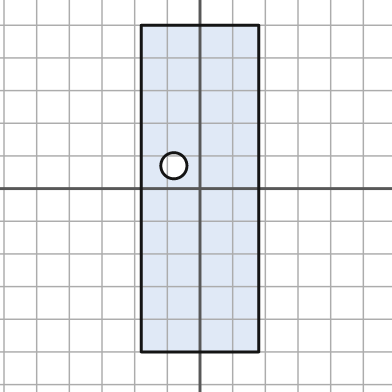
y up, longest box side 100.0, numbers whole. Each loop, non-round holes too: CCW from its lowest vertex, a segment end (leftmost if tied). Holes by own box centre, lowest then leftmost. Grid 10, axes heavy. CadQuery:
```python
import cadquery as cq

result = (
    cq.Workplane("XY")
    .moveTo(-18.0, -50.0)
    .lineTo(18.0, -50.0)
    .lineTo(18.0, 50.0)
    .lineTo(-18.0, 50.0)
    .close()
    .moveTo(-8.0, 7.0)
    .circle(4.0)
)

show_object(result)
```